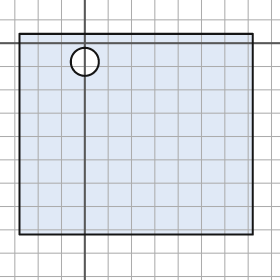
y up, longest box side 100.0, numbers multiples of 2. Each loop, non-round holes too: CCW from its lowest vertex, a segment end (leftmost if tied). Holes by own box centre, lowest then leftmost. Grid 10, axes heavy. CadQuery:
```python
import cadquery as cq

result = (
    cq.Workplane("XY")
    .moveTo(-28.0, -82.0)
    .lineTo(72.0, -82.0)
    .lineTo(72.0, 4.0)
    .lineTo(-28.0, 4.0)
    .close()
    .moveTo(0.0, -8.0)
    .circle(6.0)
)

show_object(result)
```